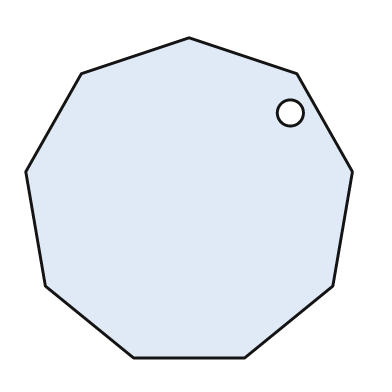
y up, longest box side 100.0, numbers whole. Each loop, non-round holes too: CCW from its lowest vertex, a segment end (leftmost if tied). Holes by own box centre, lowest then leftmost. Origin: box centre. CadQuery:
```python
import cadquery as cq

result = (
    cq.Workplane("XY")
    .moveTo(-17.0, -49.0)
    .lineTo(17.0, -49.0)
    .lineTo(44.0, -27.0)
    .lineTo(50.0, 8.0)
    .lineTo(33.0, 38.0)
    .lineTo(0.0, 49.0)
    .lineTo(-33.0, 38.0)
    .lineTo(-50.0, 8.0)
    .lineTo(-44.0, -27.0)
    .close()
    .moveTo(31.0, 26.0)
    .circle(4.0)
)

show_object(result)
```